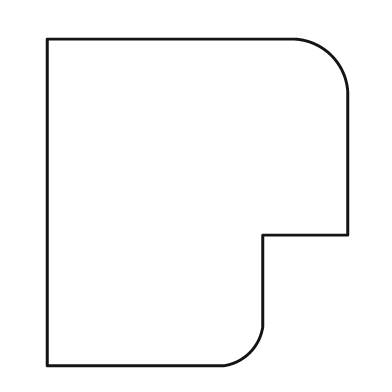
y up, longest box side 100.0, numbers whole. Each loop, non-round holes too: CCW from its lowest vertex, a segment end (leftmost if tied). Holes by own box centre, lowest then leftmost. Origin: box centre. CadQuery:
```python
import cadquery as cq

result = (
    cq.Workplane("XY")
    .moveTo(-46.0, -50.0)
    .lineTo(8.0, -50.0)
    .threePointArc((16.0, -46.0), (20.0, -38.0))
    .lineTo(20.0, -10.0)
    .lineTo(46.0, -10.0)
    .lineTo(46.0, 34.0)
    .threePointArc((41.0, 45.0), (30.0, 50.0))
    .lineTo(-46.0, 50.0)
    .close()
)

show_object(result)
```